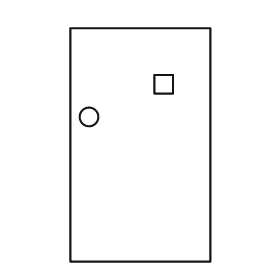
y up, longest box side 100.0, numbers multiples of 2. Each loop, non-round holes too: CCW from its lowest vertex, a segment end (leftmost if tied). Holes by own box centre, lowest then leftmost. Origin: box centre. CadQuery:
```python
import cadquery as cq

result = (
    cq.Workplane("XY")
    .moveTo(-30.0, -50.0)
    .lineTo(30.0, -50.0)
    .lineTo(30.0, 50.0)
    .lineTo(-30.0, 50.0)
    .close()
    .moveTo(-22.0, 12.0)
    .circle(4.0)
    .moveTo(6.0, 22.0)
    .lineTo(14.0, 22.0)
    .lineTo(14.0, 30.0)
    .lineTo(6.0, 30.0)
    .close()
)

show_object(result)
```